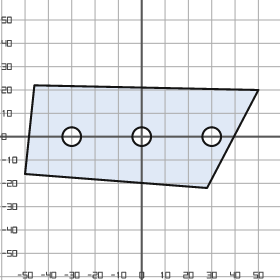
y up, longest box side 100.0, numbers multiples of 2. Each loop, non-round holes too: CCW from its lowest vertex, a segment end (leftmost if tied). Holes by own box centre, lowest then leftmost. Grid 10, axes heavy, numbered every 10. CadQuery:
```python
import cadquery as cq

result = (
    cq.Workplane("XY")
    .moveTo(28.0, -22.0)
    .lineTo(50.0, 20.0)
    .lineTo(-46.0, 22.0)
    .lineTo(-50.0, -16.0)
    .close()
    .moveTo(-30.0, 0.0)
    .circle(4.0)
    .moveTo(0.0, 0.0)
    .circle(4.0)
    .moveTo(30.0, 0.0)
    .circle(4.0)
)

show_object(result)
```